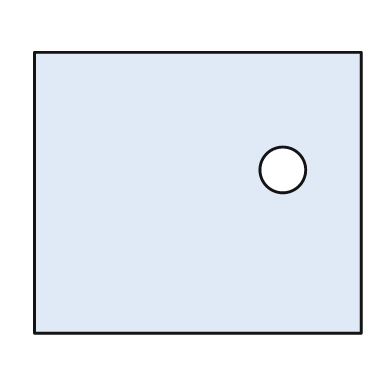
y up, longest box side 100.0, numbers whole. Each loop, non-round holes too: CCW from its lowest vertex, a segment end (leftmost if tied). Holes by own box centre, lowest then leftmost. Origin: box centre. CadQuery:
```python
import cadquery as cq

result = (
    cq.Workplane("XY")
    .moveTo(-50.0, -43.0)
    .lineTo(50.0, -43.0)
    .lineTo(50.0, 43.0)
    .lineTo(-50.0, 43.0)
    .close()
    .moveTo(26.0, 7.0)
    .circle(7.0)
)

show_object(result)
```